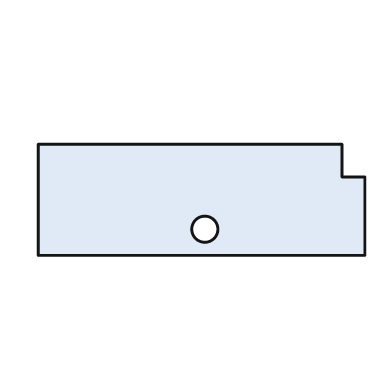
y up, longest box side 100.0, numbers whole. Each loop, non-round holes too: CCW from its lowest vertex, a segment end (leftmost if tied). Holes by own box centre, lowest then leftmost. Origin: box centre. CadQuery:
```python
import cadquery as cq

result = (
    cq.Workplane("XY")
    .moveTo(-50.0, -17.0)
    .lineTo(50.0, -17.0)
    .lineTo(50.0, 7.0)
    .lineTo(43.0, 7.0)
    .lineTo(43.0, 17.0)
    .lineTo(-50.0, 17.0)
    .close()
    .moveTo(1.0, -9.0)
    .circle(4.0)
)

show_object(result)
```